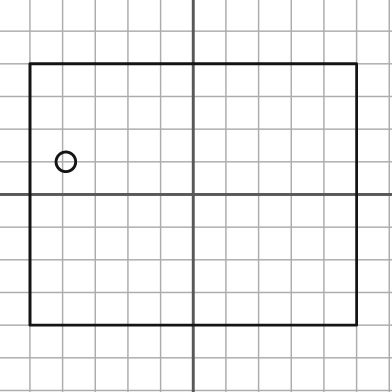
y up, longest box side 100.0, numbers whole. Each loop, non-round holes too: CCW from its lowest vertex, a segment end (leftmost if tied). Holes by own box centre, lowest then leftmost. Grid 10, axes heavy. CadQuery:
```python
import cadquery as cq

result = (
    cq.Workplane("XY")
    .moveTo(-50.0, -40.0)
    .lineTo(50.0, -40.0)
    .lineTo(50.0, 40.0)
    .lineTo(-50.0, 40.0)
    .close()
    .moveTo(-39.0, 10.0)
    .circle(3.0)
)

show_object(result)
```